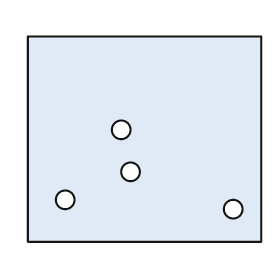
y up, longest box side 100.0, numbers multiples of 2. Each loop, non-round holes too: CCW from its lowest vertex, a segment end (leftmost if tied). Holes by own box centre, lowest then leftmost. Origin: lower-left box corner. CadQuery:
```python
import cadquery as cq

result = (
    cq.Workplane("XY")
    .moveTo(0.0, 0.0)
    .lineTo(100.0, 0.0)
    .lineTo(100.0, 88.0)
    .lineTo(0.0, 88.0)
    .close()
    .moveTo(88.0, 14.0)
    .circle(4.0)
    .moveTo(16.0, 18.0)
    .circle(4.0)
    .moveTo(44.0, 30.0)
    .circle(4.0)
    .moveTo(40.0, 48.0)
    .circle(4.0)
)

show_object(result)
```